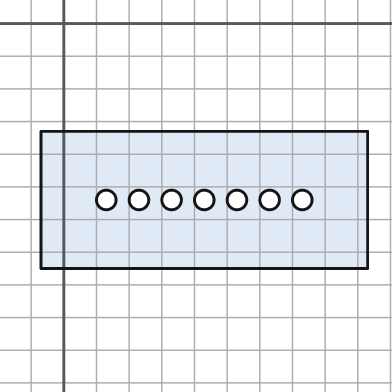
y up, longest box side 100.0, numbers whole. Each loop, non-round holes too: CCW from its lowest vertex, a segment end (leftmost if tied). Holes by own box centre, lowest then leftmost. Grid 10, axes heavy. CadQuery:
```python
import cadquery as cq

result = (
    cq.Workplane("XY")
    .moveTo(-7.0, -75.0)
    .lineTo(93.0, -75.0)
    .lineTo(93.0, -33.0)
    .lineTo(-7.0, -33.0)
    .close()
    .moveTo(13.0, -54.0)
    .circle(3.0)
    .moveTo(23.0, -54.0)
    .circle(3.0)
    .moveTo(33.0, -54.0)
    .circle(3.0)
    .moveTo(43.0, -54.0)
    .circle(3.0)
    .moveTo(53.0, -54.0)
    .circle(3.0)
    .moveTo(63.0, -54.0)
    .circle(3.0)
    .moveTo(73.0, -54.0)
    .circle(3.0)
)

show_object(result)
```